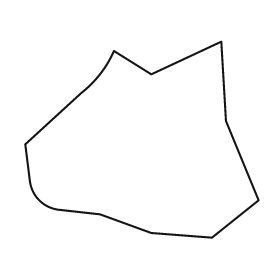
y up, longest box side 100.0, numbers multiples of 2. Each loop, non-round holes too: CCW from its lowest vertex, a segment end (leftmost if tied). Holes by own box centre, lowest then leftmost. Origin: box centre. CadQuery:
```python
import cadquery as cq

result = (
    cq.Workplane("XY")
    .moveTo(30.0, -42.0)
    .lineTo(50.0, -26.0)
    .lineTo(36.0, 8.0)
    .lineTo(34.0, 42.0)
    .lineTo(4.0, 28.0)
    .lineTo(-12.0, 38.0)
    .threePointArc((-18.0, 28.0), (-26.0, 20.0))
    .lineTo(-50.0, -2.0)
    .lineTo(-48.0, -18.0)
    .threePointArc((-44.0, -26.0), (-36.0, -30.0))
    .lineTo(-18.0, -32.0)
    .lineTo(4.0, -40.0)
    .close()
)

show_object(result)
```